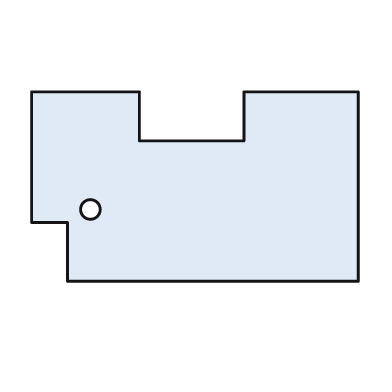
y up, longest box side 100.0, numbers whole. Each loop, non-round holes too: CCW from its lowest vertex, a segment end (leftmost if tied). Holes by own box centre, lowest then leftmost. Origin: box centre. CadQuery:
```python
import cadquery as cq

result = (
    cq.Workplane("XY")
    .moveTo(-39.0, -29.0)
    .lineTo(50.0, -29.0)
    .lineTo(50.0, 29.0)
    .lineTo(15.0, 29.0)
    .lineTo(15.0, 14.0)
    .lineTo(-17.0, 14.0)
    .lineTo(-17.0, 29.0)
    .lineTo(-50.0, 29.0)
    .lineTo(-50.0, -11.0)
    .lineTo(-39.0, -11.0)
    .close()
    .moveTo(-32.0, -7.0)
    .circle(3.0)
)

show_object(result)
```